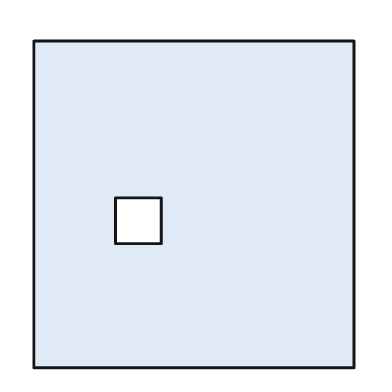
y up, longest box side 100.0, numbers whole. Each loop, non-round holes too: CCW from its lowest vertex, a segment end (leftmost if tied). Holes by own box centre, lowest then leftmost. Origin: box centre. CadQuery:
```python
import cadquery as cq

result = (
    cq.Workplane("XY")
    .moveTo(-49.0, -50.0)
    .lineTo(49.0, -50.0)
    .lineTo(49.0, 50.0)
    .lineTo(-49.0, 50.0)
    .close()
    .moveTo(-24.0, -12.0)
    .lineTo(-10.0, -12.0)
    .lineTo(-10.0, 2.0)
    .lineTo(-24.0, 2.0)
    .close()
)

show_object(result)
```